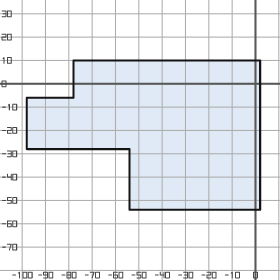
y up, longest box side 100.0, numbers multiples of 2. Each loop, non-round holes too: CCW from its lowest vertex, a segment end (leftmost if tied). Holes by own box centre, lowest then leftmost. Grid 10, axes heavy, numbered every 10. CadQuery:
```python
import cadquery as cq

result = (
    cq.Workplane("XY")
    .moveTo(-54.0, -54.0)
    .lineTo(2.0, -54.0)
    .lineTo(2.0, 10.0)
    .lineTo(-78.0, 10.0)
    .lineTo(-78.0, -6.0)
    .lineTo(-98.0, -6.0)
    .lineTo(-98.0, -28.0)
    .lineTo(-54.0, -28.0)
    .close()
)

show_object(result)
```